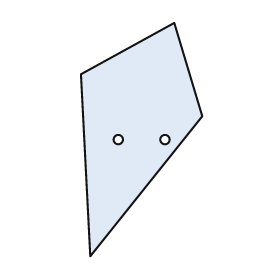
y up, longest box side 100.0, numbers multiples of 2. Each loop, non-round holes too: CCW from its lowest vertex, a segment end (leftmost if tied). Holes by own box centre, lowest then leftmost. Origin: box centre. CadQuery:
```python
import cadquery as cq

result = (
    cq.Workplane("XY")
    .moveTo(-22.0, -50.0)
    .lineTo(26.0, 10.0)
    .lineTo(14.0, 50.0)
    .lineTo(-26.0, 28.0)
    .close()
    .moveTo(-10.0, 0.0)
    .circle(2.0)
    .moveTo(10.0, 0.0)
    .circle(2.0)
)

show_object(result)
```